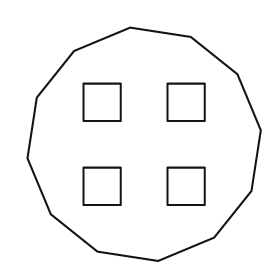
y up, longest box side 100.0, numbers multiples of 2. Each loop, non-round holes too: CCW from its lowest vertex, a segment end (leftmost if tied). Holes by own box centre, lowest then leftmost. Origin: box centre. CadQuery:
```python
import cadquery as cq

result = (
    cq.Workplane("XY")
    .moveTo(6.0, -50.0)
    .lineTo(30.0, -40.0)
    .lineTo(46.0, -20.0)
    .lineTo(50.0, 6.0)
    .lineTo(40.0, 30.0)
    .lineTo(20.0, 46.0)
    .lineTo(-6.0, 50.0)
    .lineTo(-30.0, 40.0)
    .lineTo(-46.0, 20.0)
    .lineTo(-50.0, -6.0)
    .lineTo(-40.0, -30.0)
    .lineTo(-20.0, -46.0)
    .close()
    .moveTo(-26.0, -26.0)
    .lineTo(-10.0, -26.0)
    .lineTo(-10.0, -10.0)
    .lineTo(-26.0, -10.0)
    .close()
    .moveTo(10.0, -26.0)
    .lineTo(26.0, -26.0)
    .lineTo(26.0, -10.0)
    .lineTo(10.0, -10.0)
    .close()
    .moveTo(-26.0, 10.0)
    .lineTo(-10.0, 10.0)
    .lineTo(-10.0, 26.0)
    .lineTo(-26.0, 26.0)
    .close()
    .moveTo(10.0, 10.0)
    .lineTo(26.0, 10.0)
    .lineTo(26.0, 26.0)
    .lineTo(10.0, 26.0)
    .close()
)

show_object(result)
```